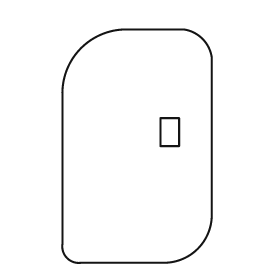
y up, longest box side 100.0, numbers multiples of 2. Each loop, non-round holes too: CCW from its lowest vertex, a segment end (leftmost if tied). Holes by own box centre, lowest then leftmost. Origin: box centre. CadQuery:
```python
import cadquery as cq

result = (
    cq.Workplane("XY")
    .moveTo(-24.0, -50.0)
    .lineTo(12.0, -50.0)
    .threePointArc((26.0, -44.0), (32.0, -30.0))
    .lineTo(32.0, 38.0)
    .threePointArc((28.0, 46.0), (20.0, 50.0))
    .lineTo(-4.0, 50.0)
    .threePointArc((-24.0, 42.0), (-32.0, 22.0))
    .lineTo(-32.0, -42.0)
    .threePointArc((-30.0, -48.0), (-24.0, -50.0))
    .close()
    .moveTo(10.0, 0.0)
    .lineTo(18.0, 0.0)
    .lineTo(18.0, 12.0)
    .lineTo(10.0, 12.0)
    .close()
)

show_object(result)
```